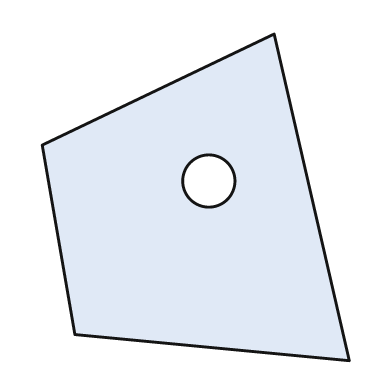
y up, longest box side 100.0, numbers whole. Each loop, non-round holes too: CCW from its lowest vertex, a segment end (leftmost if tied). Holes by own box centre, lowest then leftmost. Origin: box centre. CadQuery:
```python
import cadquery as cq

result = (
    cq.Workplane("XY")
    .moveTo(47.0, -50.0)
    .lineTo(24.0, 50.0)
    .lineTo(-47.0, 16.0)
    .lineTo(-37.0, -42.0)
    .close()
    .moveTo(4.0, 5.0)
    .circle(8.0)
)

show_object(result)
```